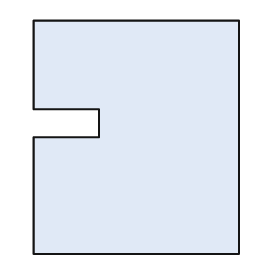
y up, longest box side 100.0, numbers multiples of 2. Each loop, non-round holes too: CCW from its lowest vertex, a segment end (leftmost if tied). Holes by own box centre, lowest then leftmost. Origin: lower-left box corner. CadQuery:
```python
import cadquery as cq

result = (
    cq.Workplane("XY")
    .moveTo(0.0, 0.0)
    .lineTo(88.0, 0.0)
    .lineTo(88.0, 100.0)
    .lineTo(0.0, 100.0)
    .lineTo(0.0, 62.0)
    .lineTo(28.0, 62.0)
    .lineTo(28.0, 50.0)
    .lineTo(0.0, 50.0)
    .close()
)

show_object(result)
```